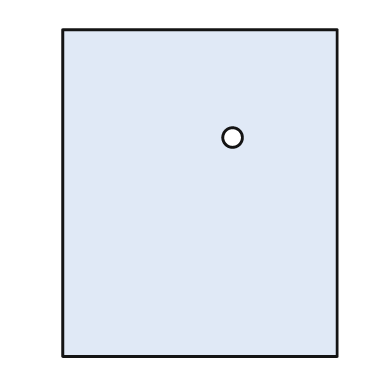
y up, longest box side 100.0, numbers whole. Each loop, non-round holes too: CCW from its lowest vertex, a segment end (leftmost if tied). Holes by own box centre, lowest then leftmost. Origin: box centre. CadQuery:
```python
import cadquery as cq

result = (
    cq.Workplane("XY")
    .moveTo(-42.0, -50.0)
    .lineTo(42.0, -50.0)
    .lineTo(42.0, 50.0)
    .lineTo(-42.0, 50.0)
    .close()
    .moveTo(10.0, 17.0)
    .circle(3.0)
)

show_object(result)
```